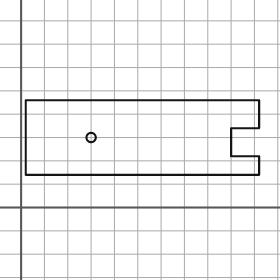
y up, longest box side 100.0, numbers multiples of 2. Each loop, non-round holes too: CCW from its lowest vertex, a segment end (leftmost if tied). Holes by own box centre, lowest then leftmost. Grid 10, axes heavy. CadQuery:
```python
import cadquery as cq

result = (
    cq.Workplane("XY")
    .moveTo(2.0, 14.0)
    .lineTo(102.0, 14.0)
    .lineTo(102.0, 22.0)
    .lineTo(90.0, 22.0)
    .lineTo(90.0, 34.0)
    .lineTo(102.0, 34.0)
    .lineTo(102.0, 46.0)
    .lineTo(2.0, 46.0)
    .close()
    .moveTo(30.0, 30.0)
    .circle(2.0)
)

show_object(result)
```